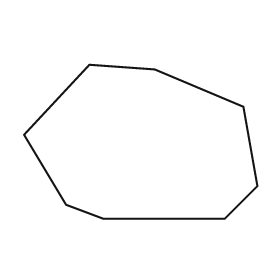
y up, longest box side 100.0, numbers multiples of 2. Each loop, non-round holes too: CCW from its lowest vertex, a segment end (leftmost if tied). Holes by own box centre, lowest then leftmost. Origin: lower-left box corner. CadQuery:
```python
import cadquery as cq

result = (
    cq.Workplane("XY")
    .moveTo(34.0, 0.0)
    .lineTo(86.0, 0.0)
    .lineTo(100.0, 14.0)
    .lineTo(94.0, 48.0)
    .lineTo(56.0, 64.0)
    .lineTo(28.0, 66.0)
    .lineTo(0.0, 36.0)
    .lineTo(18.0, 6.0)
    .close()
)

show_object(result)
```